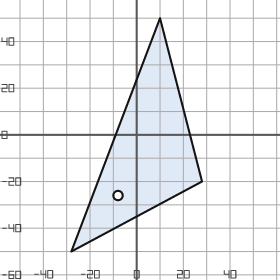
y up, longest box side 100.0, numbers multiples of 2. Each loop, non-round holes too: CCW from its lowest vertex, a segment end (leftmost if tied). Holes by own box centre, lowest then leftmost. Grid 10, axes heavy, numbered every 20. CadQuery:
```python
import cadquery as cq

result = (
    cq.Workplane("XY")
    .moveTo(-28.0, -50.0)
    .lineTo(28.0, -20.0)
    .lineTo(10.0, 50.0)
    .close()
    .moveTo(-8.0, -26.0)
    .circle(2.0)
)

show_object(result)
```